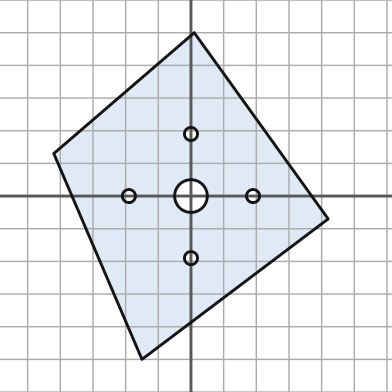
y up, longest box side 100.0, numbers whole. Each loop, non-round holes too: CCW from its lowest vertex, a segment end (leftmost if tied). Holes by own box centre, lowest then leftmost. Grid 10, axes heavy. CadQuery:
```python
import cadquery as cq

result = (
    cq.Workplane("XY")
    .moveTo(-15.0, -50.0)
    .lineTo(42.0, -7.0)
    .lineTo(1.0, 50.0)
    .lineTo(-42.0, 13.0)
    .close()
    .moveTo(0.0, -19.0)
    .circle(2.0)
    .moveTo(-19.0, 0.0)
    .circle(2.0)
    .moveTo(0.0, 0.0)
    .circle(5.0)
    .moveTo(19.0, 0.0)
    .circle(2.0)
    .moveTo(0.0, 19.0)
    .circle(2.0)
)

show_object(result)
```